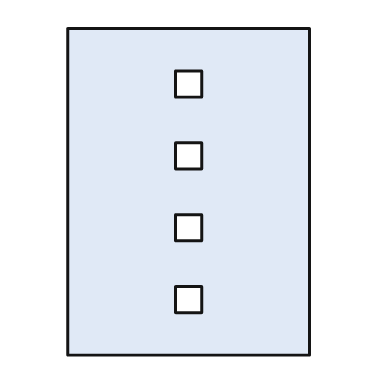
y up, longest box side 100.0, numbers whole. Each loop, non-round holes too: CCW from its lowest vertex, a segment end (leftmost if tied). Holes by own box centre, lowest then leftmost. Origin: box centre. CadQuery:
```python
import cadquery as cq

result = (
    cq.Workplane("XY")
    .moveTo(-37.0, -50.0)
    .lineTo(37.0, -50.0)
    .lineTo(37.0, 50.0)
    .lineTo(-37.0, 50.0)
    .close()
    .moveTo(-4.0, -37.0)
    .lineTo(4.0, -37.0)
    .lineTo(4.0, -29.0)
    .lineTo(-4.0, -29.0)
    .close()
    .moveTo(-4.0, -15.0)
    .lineTo(4.0, -15.0)
    .lineTo(4.0, -7.0)
    .lineTo(-4.0, -7.0)
    .close()
    .moveTo(-4.0, 7.0)
    .lineTo(4.0, 7.0)
    .lineTo(4.0, 15.0)
    .lineTo(-4.0, 15.0)
    .close()
    .moveTo(-4.0, 29.0)
    .lineTo(4.0, 29.0)
    .lineTo(4.0, 37.0)
    .lineTo(-4.0, 37.0)
    .close()
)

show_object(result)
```